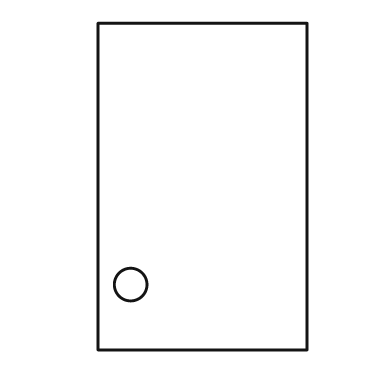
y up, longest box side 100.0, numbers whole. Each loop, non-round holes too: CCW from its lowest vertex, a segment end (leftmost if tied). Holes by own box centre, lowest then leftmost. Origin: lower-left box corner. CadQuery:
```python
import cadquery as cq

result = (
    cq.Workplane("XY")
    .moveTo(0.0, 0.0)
    .lineTo(64.0, 0.0)
    .lineTo(64.0, 100.0)
    .lineTo(0.0, 100.0)
    .close()
    .moveTo(10.0, 20.0)
    .circle(5.0)
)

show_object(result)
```